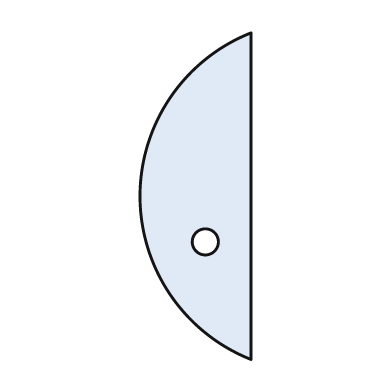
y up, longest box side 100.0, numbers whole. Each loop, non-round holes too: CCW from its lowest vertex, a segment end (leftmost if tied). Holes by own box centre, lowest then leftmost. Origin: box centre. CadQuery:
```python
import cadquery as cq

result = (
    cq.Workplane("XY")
    .moveTo(17.0, -50.0)
    .lineTo(17.0, 50.0)
    .threePointArc((-17.0, 0.0), (17.0, -50.0))
    .close()
    .moveTo(3.0, -14.0)
    .circle(4.0)
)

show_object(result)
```